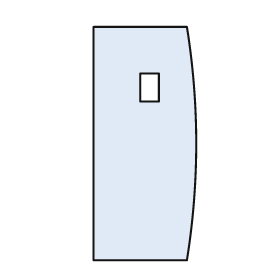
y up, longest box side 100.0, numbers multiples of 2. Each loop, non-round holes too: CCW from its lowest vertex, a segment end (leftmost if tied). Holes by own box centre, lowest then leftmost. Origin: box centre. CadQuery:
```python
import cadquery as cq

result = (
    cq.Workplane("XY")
    .moveTo(-22.0, -50.0)
    .lineTo(18.0, -50.0)
    .threePointArc((22.0, 0.0), (18.0, 50.0))
    .lineTo(-22.0, 50.0)
    .close()
    .moveTo(-2.0, 18.0)
    .lineTo(6.0, 18.0)
    .lineTo(6.0, 30.0)
    .lineTo(-2.0, 30.0)
    .close()
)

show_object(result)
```